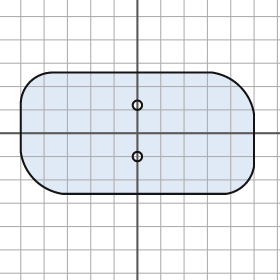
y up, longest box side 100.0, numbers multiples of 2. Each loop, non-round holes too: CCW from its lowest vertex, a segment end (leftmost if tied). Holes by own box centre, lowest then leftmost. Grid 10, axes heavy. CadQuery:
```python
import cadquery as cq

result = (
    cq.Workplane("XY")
    .moveTo(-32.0, -26.0)
    .lineTo(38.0, -26.0)
    .threePointArc((46.0, -22.0), (50.0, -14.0))
    .lineTo(50.0, 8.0)
    .threePointArc((44.0, 20.0), (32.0, 26.0))
    .lineTo(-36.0, 26.0)
    .threePointArc((-46.0, 22.0), (-50.0, 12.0))
    .lineTo(-50.0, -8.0)
    .threePointArc((-44.0, -20.0), (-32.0, -26.0))
    .close()
    .moveTo(0.0, -10.0)
    .circle(2.0)
    .moveTo(0.0, 12.0)
    .circle(2.0)
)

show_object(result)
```